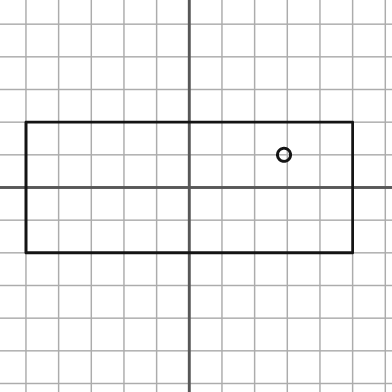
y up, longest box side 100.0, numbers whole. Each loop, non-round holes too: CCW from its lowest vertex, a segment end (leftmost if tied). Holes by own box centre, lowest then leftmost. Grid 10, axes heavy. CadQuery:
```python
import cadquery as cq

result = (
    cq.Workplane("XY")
    .moveTo(-50.0, -20.0)
    .lineTo(50.0, -20.0)
    .lineTo(50.0, 20.0)
    .lineTo(-50.0, 20.0)
    .close()
    .moveTo(29.0, 10.0)
    .circle(2.0)
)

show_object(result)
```